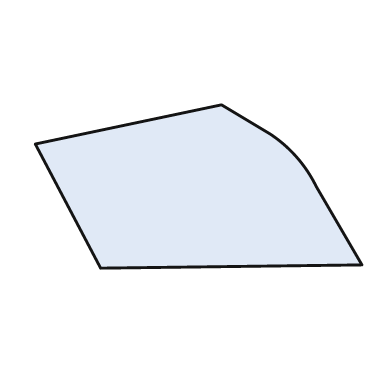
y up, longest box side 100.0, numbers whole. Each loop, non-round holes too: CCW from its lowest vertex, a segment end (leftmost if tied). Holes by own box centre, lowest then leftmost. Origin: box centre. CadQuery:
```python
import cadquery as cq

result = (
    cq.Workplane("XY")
    .moveTo(-30.0, -25.0)
    .lineTo(50.0, -24.0)
    .lineTo(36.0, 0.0)
    .threePointArc((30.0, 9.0), (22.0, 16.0))
    .lineTo(7.0, 25.0)
    .lineTo(-50.0, 13.0)
    .close()
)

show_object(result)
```